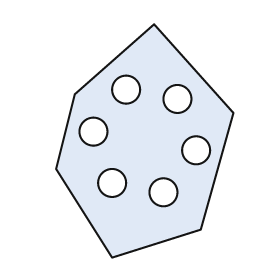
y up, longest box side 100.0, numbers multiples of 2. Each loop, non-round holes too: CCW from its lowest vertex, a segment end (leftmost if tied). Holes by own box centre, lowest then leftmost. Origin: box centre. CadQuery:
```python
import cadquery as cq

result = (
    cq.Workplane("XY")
    .moveTo(-14.0, -50.0)
    .lineTo(24.0, -38.0)
    .lineTo(38.0, 12.0)
    .lineTo(4.0, 50.0)
    .lineTo(-30.0, 20.0)
    .lineTo(-38.0, -12.0)
    .close()
    .moveTo(8.0, -22.0)
    .circle(6.0)
    .moveTo(-14.0, -18.0)
    .circle(6.0)
    .moveTo(22.0, -4.0)
    .circle(6.0)
    .moveTo(-22.0, 4.0)
    .circle(6.0)
    .moveTo(14.0, 18.0)
    .circle(6.0)
    .moveTo(-8.0, 22.0)
    .circle(6.0)
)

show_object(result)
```